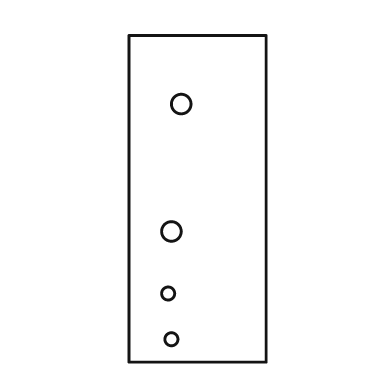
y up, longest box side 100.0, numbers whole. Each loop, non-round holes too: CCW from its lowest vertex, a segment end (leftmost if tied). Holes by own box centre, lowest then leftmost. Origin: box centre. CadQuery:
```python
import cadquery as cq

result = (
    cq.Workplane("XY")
    .moveTo(-21.0, -50.0)
    .lineTo(21.0, -50.0)
    .lineTo(21.0, 50.0)
    .lineTo(-21.0, 50.0)
    .close()
    .moveTo(-8.0, -43.0)
    .circle(2.0)
    .moveTo(-9.0, -29.0)
    .circle(2.0)
    .moveTo(-8.0, -10.0)
    .circle(3.0)
    .moveTo(-5.0, 29.0)
    .circle(3.0)
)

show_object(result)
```